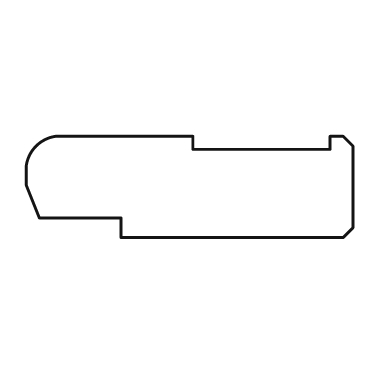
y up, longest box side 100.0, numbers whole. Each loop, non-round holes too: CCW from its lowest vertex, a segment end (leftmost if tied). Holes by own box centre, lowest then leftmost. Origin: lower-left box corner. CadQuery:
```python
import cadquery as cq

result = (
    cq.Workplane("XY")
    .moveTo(29.0, 0.0)
    .lineTo(97.0, 0.0)
    .lineTo(100.0, 3.0)
    .lineTo(100.0, 28.0)
    .lineTo(97.0, 31.0)
    .lineTo(93.0, 31.0)
    .lineTo(93.0, 27.0)
    .lineTo(51.0, 27.0)
    .lineTo(51.0, 31.0)
    .lineTo(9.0, 31.0)
    .threePointArc((3.0, 28.0), (0.0, 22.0))
    .lineTo(0.0, 16.0)
    .lineTo(4.0, 6.0)
    .lineTo(29.0, 6.0)
    .close()
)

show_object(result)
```